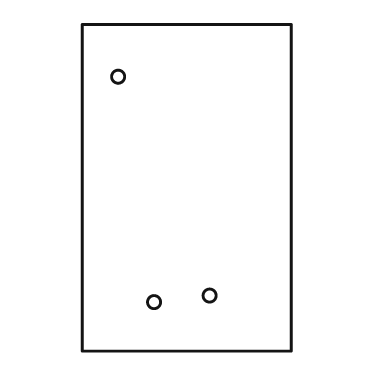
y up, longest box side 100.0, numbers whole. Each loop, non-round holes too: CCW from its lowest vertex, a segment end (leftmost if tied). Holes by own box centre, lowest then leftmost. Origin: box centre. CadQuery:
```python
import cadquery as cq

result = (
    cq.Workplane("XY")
    .moveTo(-32.0, -50.0)
    .lineTo(32.0, -50.0)
    .lineTo(32.0, 50.0)
    .lineTo(-32.0, 50.0)
    .close()
    .moveTo(-10.0, -35.0)
    .circle(2.0)
    .moveTo(7.0, -33.0)
    .circle(2.0)
    .moveTo(-21.0, 34.0)
    .circle(2.0)
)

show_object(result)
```